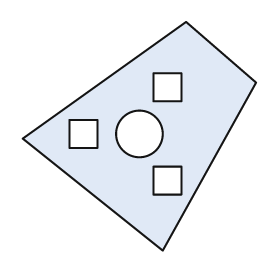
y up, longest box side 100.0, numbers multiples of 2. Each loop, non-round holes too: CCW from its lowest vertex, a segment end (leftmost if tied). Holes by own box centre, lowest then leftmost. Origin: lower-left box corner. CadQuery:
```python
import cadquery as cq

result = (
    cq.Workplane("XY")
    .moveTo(60.0, 0.0)
    .lineTo(100.0, 72.0)
    .lineTo(70.0, 98.0)
    .lineTo(0.0, 48.0)
    .close()
    .moveTo(56.0, 24.0)
    .lineTo(68.0, 24.0)
    .lineTo(68.0, 36.0)
    .lineTo(56.0, 36.0)
    .close()
    .moveTo(20.0, 44.0)
    .lineTo(32.0, 44.0)
    .lineTo(32.0, 56.0)
    .lineTo(20.0, 56.0)
    .close()
    .moveTo(50.0, 50.0)
    .circle(10.0)
    .moveTo(56.0, 64.0)
    .lineTo(68.0, 64.0)
    .lineTo(68.0, 76.0)
    .lineTo(56.0, 76.0)
    .close()
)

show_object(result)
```